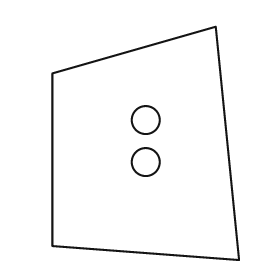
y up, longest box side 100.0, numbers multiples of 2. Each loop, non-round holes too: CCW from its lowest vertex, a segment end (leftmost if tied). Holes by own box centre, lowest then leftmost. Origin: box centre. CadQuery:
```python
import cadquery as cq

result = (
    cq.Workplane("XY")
    .moveTo(40.0, -50.0)
    .lineTo(30.0, 50.0)
    .lineTo(-40.0, 30.0)
    .lineTo(-40.0, -44.0)
    .close()
    .moveTo(0.0, -8.0)
    .circle(6.0)
    .moveTo(0.0, 10.0)
    .circle(6.0)
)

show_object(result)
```